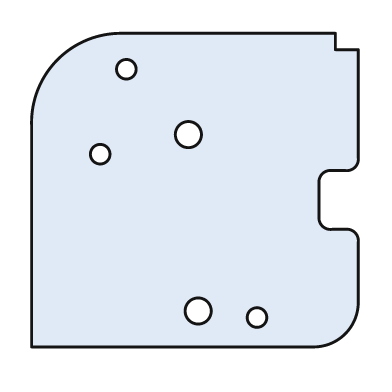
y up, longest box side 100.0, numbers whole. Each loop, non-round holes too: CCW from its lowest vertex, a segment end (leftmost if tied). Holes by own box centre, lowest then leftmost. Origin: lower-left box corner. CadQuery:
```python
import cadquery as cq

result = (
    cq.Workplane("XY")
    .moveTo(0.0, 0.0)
    .lineTo(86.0, 0.0)
    .threePointArc((96.0, 4.0), (100.0, 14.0))
    .lineTo(100.0, 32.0)
    .threePointArc((99.0, 35.0), (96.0, 36.0))
    .lineTo(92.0, 36.0)
    .threePointArc((89.0, 37.0), (88.0, 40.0))
    .lineTo(88.0, 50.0)
    .threePointArc((89.0, 53.0), (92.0, 54.0))
    .lineTo(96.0, 54.0)
    .threePointArc((99.0, 55.0), (100.0, 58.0))
    .lineTo(100.0, 91.0)
    .lineTo(93.0, 91.0)
    .lineTo(93.0, 96.0)
    .lineTo(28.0, 96.0)
    .threePointArc((8.0, 88.0), (0.0, 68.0))
    .close()
    .moveTo(69.0, 9.0)
    .circle(3.0)
    .moveTo(51.0, 11.0)
    .circle(4.0)
    .moveTo(21.0, 59.0)
    .circle(3.0)
    .moveTo(48.0, 65.0)
    .circle(4.0)
    .moveTo(29.0, 85.0)
    .circle(3.0)
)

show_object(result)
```